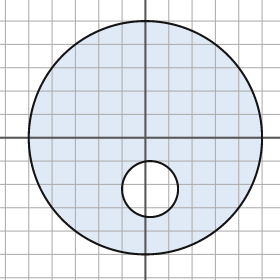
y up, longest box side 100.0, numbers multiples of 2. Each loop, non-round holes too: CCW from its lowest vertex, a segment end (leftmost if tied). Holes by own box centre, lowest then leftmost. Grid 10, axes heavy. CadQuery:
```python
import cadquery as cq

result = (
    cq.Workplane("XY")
    .moveTo(0.0, 0.0)
    .circle(50.0)
    .moveTo(2.0, -22.0)
    .circle(12.0)
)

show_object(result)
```